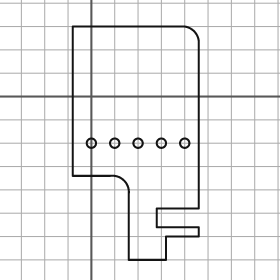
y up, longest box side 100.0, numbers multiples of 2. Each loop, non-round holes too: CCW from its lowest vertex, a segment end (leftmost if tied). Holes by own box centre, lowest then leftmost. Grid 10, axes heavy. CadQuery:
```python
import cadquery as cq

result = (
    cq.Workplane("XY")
    .moveTo(16.0, -70.0)
    .lineTo(32.0, -70.0)
    .lineTo(32.0, -60.0)
    .lineTo(46.0, -60.0)
    .lineTo(46.0, -56.0)
    .lineTo(28.0, -56.0)
    .lineTo(28.0, -48.0)
    .lineTo(46.0, -48.0)
    .lineTo(46.0, 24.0)
    .threePointArc((44.0, 28.0), (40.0, 30.0))
    .lineTo(-8.0, 30.0)
    .lineTo(-8.0, -34.0)
    .lineTo(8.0, -34.0)
    .threePointArc((14.0, -36.0), (16.0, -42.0))
    .close()
    .moveTo(0.0, -20.0)
    .circle(2.0)
    .moveTo(10.0, -20.0)
    .circle(2.0)
    .moveTo(20.0, -20.0)
    .circle(2.0)
    .moveTo(30.0, -20.0)
    .circle(2.0)
    .moveTo(40.0, -20.0)
    .circle(2.0)
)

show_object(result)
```